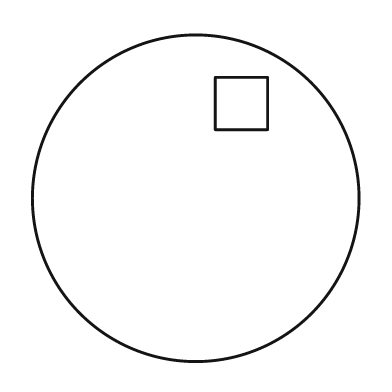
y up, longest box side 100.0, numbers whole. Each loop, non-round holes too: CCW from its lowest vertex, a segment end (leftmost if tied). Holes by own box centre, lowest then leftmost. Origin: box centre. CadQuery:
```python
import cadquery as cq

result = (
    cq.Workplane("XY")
    .moveTo(0.0, 0.0)
    .circle(50.0)
    .moveTo(6.0, 21.0)
    .lineTo(22.0, 21.0)
    .lineTo(22.0, 37.0)
    .lineTo(6.0, 37.0)
    .close()
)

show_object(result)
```